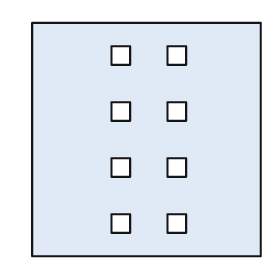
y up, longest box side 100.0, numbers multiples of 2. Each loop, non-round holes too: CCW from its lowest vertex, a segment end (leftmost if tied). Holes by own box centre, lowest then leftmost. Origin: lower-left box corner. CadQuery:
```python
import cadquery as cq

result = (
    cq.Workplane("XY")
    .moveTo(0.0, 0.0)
    .lineTo(98.0, 0.0)
    .lineTo(98.0, 100.0)
    .lineTo(0.0, 100.0)
    .close()
    .moveTo(34.0, 10.0)
    .lineTo(42.0, 10.0)
    .lineTo(42.0, 18.0)
    .lineTo(34.0, 18.0)
    .close()
    .moveTo(58.0, 10.0)
    .lineTo(66.0, 10.0)
    .lineTo(66.0, 18.0)
    .lineTo(58.0, 18.0)
    .close()
    .moveTo(34.0, 34.0)
    .lineTo(42.0, 34.0)
    .lineTo(42.0, 42.0)
    .lineTo(34.0, 42.0)
    .close()
    .moveTo(58.0, 34.0)
    .lineTo(66.0, 34.0)
    .lineTo(66.0, 42.0)
    .lineTo(58.0, 42.0)
    .close()
    .moveTo(34.0, 58.0)
    .lineTo(42.0, 58.0)
    .lineTo(42.0, 66.0)
    .lineTo(34.0, 66.0)
    .close()
    .moveTo(58.0, 58.0)
    .lineTo(66.0, 58.0)
    .lineTo(66.0, 66.0)
    .lineTo(58.0, 66.0)
    .close()
    .moveTo(34.0, 82.0)
    .lineTo(42.0, 82.0)
    .lineTo(42.0, 90.0)
    .lineTo(34.0, 90.0)
    .close()
    .moveTo(58.0, 82.0)
    .lineTo(66.0, 82.0)
    .lineTo(66.0, 90.0)
    .lineTo(58.0, 90.0)
    .close()
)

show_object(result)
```